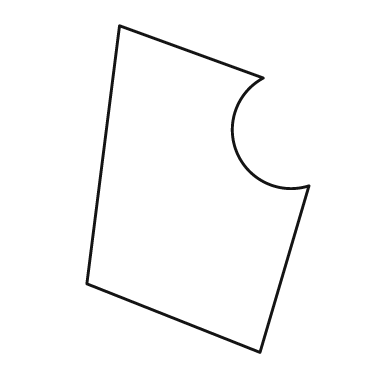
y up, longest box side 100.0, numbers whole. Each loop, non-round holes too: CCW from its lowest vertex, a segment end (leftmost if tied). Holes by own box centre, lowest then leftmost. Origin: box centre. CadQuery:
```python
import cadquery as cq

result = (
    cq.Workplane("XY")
    .moveTo(19.0, -50.0)
    .lineTo(34.0, 1.0)
    .threePointArc((12.0, 11.0), (20.0, 34.0))
    .lineTo(-24.0, 50.0)
    .lineTo(-34.0, -29.0)
    .close()
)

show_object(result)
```